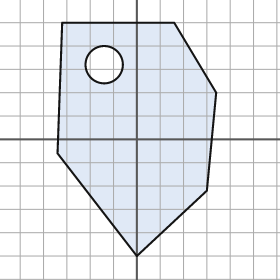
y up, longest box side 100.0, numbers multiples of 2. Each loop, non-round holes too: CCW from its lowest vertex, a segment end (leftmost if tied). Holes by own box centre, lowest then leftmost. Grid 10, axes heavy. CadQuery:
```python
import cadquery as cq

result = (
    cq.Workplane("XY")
    .moveTo(0.0, -50.0)
    .lineTo(30.0, -22.0)
    .lineTo(34.0, 20.0)
    .lineTo(16.0, 50.0)
    .lineTo(-32.0, 50.0)
    .lineTo(-34.0, -6.0)
    .close()
    .moveTo(-14.0, 32.0)
    .circle(8.0)
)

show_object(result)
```